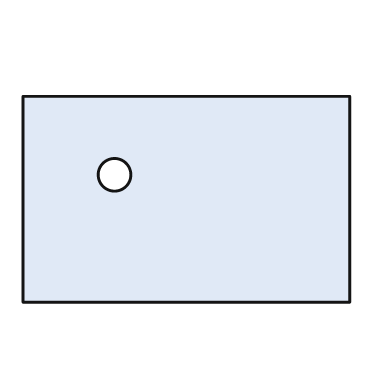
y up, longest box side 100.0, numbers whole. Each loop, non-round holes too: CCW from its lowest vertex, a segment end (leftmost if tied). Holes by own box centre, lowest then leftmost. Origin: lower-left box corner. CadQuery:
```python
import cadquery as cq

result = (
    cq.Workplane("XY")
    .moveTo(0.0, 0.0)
    .lineTo(100.0, 0.0)
    .lineTo(100.0, 63.0)
    .lineTo(0.0, 63.0)
    .close()
    .moveTo(28.0, 39.0)
    .circle(5.0)
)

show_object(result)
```